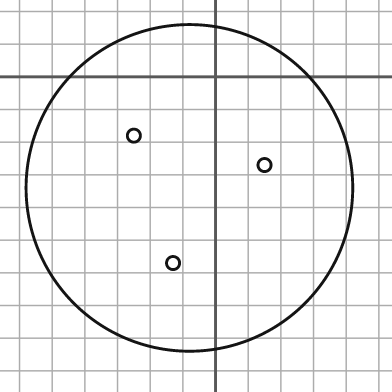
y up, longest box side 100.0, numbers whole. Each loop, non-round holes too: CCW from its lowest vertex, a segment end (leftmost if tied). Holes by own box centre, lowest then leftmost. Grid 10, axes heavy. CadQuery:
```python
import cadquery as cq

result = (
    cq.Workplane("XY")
    .moveTo(-8.0, -34.0)
    .circle(50.0)
    .moveTo(-13.0, -57.0)
    .circle(2.0)
    .moveTo(15.0, -27.0)
    .circle(2.0)
    .moveTo(-25.0, -18.0)
    .circle(2.0)
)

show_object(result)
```